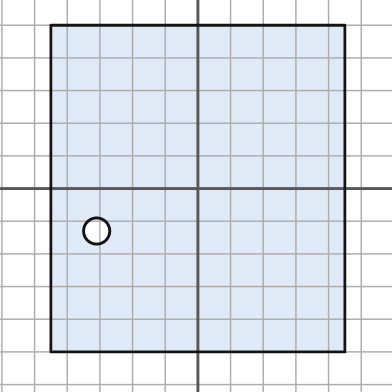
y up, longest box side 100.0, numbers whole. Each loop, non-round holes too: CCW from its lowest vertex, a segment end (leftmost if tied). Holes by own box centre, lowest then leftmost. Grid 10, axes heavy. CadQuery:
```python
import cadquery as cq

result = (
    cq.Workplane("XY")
    .moveTo(-45.0, -50.0)
    .lineTo(45.0, -50.0)
    .lineTo(45.0, 50.0)
    .lineTo(-45.0, 50.0)
    .close()
    .moveTo(-31.0, -13.0)
    .circle(4.0)
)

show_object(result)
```